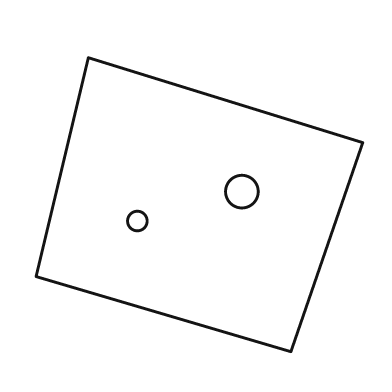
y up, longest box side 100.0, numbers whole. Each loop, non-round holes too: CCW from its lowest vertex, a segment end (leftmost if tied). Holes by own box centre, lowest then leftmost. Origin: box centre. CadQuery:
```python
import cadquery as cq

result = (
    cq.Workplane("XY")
    .moveTo(28.0, -45.0)
    .lineTo(50.0, 19.0)
    .lineTo(-34.0, 45.0)
    .lineTo(-50.0, -22.0)
    .close()
    .moveTo(-19.0, -5.0)
    .circle(3.0)
    .moveTo(13.0, 4.0)
    .circle(5.0)
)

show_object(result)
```